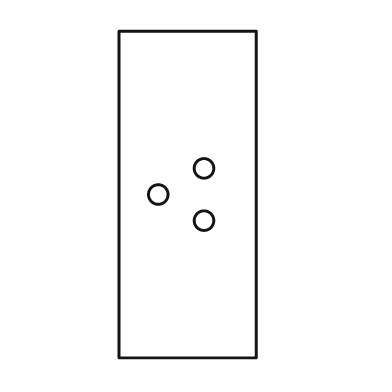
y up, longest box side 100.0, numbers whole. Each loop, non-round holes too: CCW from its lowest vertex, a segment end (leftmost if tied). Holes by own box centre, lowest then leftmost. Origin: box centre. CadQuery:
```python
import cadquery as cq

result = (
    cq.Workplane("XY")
    .moveTo(-21.0, -50.0)
    .lineTo(21.0, -50.0)
    .lineTo(21.0, 50.0)
    .lineTo(-21.0, 50.0)
    .close()
    .moveTo(5.0, -8.0)
    .circle(3.0)
    .moveTo(-9.0, 0.0)
    .circle(3.0)
    .moveTo(5.0, 8.0)
    .circle(3.0)
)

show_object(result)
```